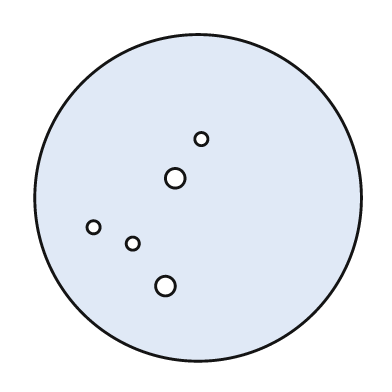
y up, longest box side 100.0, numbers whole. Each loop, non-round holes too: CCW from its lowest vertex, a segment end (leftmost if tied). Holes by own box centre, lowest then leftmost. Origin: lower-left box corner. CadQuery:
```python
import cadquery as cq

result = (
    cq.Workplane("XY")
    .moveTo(50.0, 50.0)
    .circle(50.0)
    .moveTo(40.0, 23.0)
    .circle(3.0)
    .moveTo(30.0, 36.0)
    .circle(2.0)
    .moveTo(18.0, 41.0)
    .circle(2.0)
    .moveTo(43.0, 56.0)
    .circle(3.0)
    .moveTo(51.0, 68.0)
    .circle(2.0)
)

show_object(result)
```